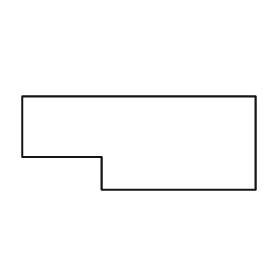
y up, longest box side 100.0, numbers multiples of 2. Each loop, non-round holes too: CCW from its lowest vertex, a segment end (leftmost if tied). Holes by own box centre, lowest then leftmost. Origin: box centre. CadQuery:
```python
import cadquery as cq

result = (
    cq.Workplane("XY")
    .moveTo(-16.0, -20.0)
    .lineTo(50.0, -20.0)
    .lineTo(50.0, 20.0)
    .lineTo(-50.0, 20.0)
    .lineTo(-50.0, -6.0)
    .lineTo(-16.0, -6.0)
    .close()
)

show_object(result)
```